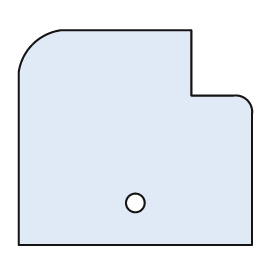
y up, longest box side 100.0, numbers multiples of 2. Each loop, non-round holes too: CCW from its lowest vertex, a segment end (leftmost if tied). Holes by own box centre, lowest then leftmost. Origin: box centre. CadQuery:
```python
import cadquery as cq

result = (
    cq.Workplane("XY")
    .moveTo(-50.0, -46.0)
    .lineTo(50.0, -46.0)
    .lineTo(50.0, 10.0)
    .threePointArc((48.0, 16.0), (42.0, 18.0))
    .lineTo(24.0, 18.0)
    .lineTo(24.0, 46.0)
    .lineTo(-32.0, 46.0)
    .threePointArc((-44.0, 40.0), (-50.0, 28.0))
    .close()
    .moveTo(0.0, -28.0)
    .circle(4.0)
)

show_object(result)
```